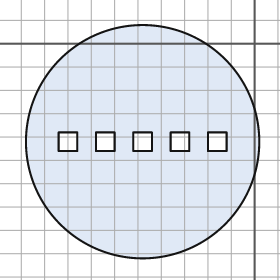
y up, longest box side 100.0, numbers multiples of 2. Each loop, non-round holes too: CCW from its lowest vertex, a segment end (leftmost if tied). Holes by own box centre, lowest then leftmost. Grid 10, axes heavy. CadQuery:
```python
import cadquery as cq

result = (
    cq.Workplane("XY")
    .moveTo(-48.0, -42.0)
    .circle(50.0)
    .moveTo(-84.0, -46.0)
    .lineTo(-76.0, -46.0)
    .lineTo(-76.0, -38.0)
    .lineTo(-84.0, -38.0)
    .close()
    .moveTo(-68.0, -46.0)
    .lineTo(-60.0, -46.0)
    .lineTo(-60.0, -38.0)
    .lineTo(-68.0, -38.0)
    .close()
    .moveTo(-52.0, -46.0)
    .lineTo(-44.0, -46.0)
    .lineTo(-44.0, -38.0)
    .lineTo(-52.0, -38.0)
    .close()
    .moveTo(-36.0, -46.0)
    .lineTo(-28.0, -46.0)
    .lineTo(-28.0, -38.0)
    .lineTo(-36.0, -38.0)
    .close()
    .moveTo(-20.0, -46.0)
    .lineTo(-12.0, -46.0)
    .lineTo(-12.0, -38.0)
    .lineTo(-20.0, -38.0)
    .close()
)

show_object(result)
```